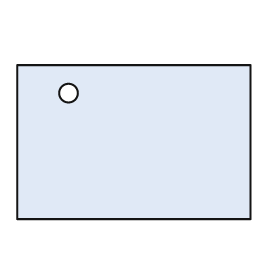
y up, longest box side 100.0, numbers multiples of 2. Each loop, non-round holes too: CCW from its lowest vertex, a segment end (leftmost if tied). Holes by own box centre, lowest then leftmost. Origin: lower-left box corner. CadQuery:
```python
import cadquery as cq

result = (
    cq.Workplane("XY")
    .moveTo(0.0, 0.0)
    .lineTo(100.0, 0.0)
    .lineTo(100.0, 66.0)
    .lineTo(0.0, 66.0)
    .close()
    .moveTo(22.0, 54.0)
    .circle(4.0)
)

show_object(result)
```